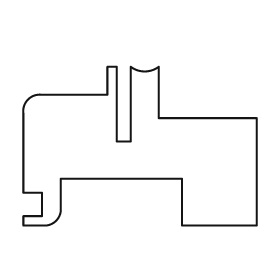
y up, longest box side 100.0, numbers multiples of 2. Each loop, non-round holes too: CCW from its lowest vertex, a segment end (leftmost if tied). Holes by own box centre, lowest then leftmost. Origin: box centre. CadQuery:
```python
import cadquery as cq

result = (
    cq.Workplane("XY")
    .moveTo(-50.0, -34.0)
    .lineTo(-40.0, -34.0)
    .threePointArc((-36.0, -32.0), (-34.0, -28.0))
    .lineTo(-34.0, -14.0)
    .lineTo(18.0, -14.0)
    .lineTo(18.0, -34.0)
    .lineTo(50.0, -34.0)
    .lineTo(50.0, 12.0)
    .lineTo(8.0, 12.0)
    .lineTo(8.0, 34.0)
    .threePointArc((2.0, 32.0), (-4.0, 34.0))
    .lineTo(-4.0, 2.0)
    .lineTo(-10.0, 2.0)
    .lineTo(-10.0, 34.0)
    .lineTo(-14.0, 34.0)
    .lineTo(-14.0, 22.0)
    .lineTo(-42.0, 22.0)
    .threePointArc((-48.0, 20.0), (-50.0, 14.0))
    .lineTo(-50.0, -20.0)
    .lineTo(-42.0, -20.0)
    .lineTo(-42.0, -30.0)
    .lineTo(-50.0, -30.0)
    .close()
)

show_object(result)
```